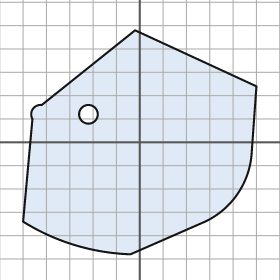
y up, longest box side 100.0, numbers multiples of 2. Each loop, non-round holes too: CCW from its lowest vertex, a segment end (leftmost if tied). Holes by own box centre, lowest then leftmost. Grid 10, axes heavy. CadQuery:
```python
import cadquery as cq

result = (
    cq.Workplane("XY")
    .moveTo(-4.0, -48.0)
    .lineTo(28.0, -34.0)
    .threePointArc((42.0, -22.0), (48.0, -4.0))
    .lineTo(50.0, 24.0)
    .lineTo(-2.0, 48.0)
    .lineTo(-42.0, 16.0)
    .threePointArc((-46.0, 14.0), (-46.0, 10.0))
    .lineTo(-50.0, -34.0)
    .threePointArc((-28.0, -44.0), (-4.0, -48.0))
    .close()
    .moveTo(-22.0, 12.0)
    .circle(4.0)
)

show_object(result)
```